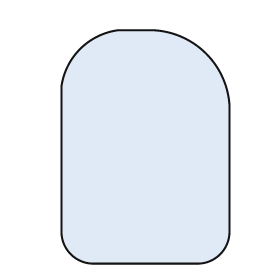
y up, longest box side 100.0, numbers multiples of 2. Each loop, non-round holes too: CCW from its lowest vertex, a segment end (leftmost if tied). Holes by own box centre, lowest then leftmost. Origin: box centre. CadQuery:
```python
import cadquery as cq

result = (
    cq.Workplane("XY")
    .moveTo(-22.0, -50.0)
    .lineTo(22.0, -50.0)
    .threePointArc((32.0, -46.0), (36.0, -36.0))
    .lineTo(36.0, 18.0)
    .threePointArc((26.0, 40.0), (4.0, 50.0))
    .lineTo(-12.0, 50.0)
    .threePointArc((-28.0, 42.0), (-36.0, 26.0))
    .lineTo(-36.0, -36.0)
    .threePointArc((-32.0, -46.0), (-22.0, -50.0))
    .close()
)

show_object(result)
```